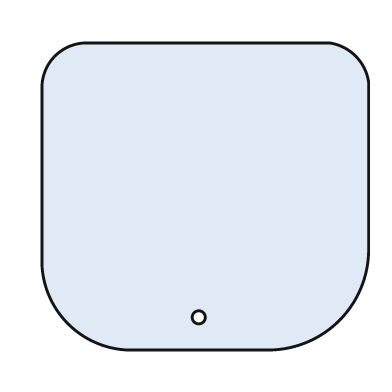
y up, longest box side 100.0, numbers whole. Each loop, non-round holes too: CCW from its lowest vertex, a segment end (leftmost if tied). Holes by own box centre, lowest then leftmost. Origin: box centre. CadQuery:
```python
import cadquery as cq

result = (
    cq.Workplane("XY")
    .moveTo(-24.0, -47.0)
    .lineTo(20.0, -47.0)
    .threePointArc((41.0, -38.0), (50.0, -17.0))
    .lineTo(50.0, 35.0)
    .threePointArc((46.0, 43.0), (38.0, 47.0))
    .lineTo(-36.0, 47.0)
    .threePointArc((-46.0, 43.0), (-50.0, 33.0))
    .lineTo(-50.0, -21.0)
    .threePointArc((-42.0, -39.0), (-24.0, -47.0))
    .close()
    .moveTo(-2.0, -37.0)
    .circle(2.0)
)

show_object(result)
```